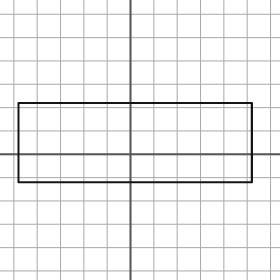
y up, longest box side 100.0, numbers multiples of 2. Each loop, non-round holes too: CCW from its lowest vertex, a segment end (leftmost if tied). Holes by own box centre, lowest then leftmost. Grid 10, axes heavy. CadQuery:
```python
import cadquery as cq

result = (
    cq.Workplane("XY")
    .moveTo(-48.0, -12.0)
    .lineTo(52.0, -12.0)
    .lineTo(52.0, 22.0)
    .lineTo(-48.0, 22.0)
    .close()
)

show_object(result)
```